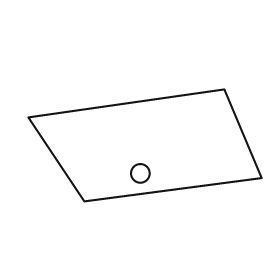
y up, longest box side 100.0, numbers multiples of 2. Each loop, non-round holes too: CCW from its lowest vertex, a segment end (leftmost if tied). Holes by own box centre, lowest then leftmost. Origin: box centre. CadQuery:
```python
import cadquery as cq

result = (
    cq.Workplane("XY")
    .moveTo(-26.0, -24.0)
    .lineTo(50.0, -14.0)
    .lineTo(34.0, 24.0)
    .lineTo(-50.0, 12.0)
    .close()
    .moveTo(-2.0, -12.0)
    .circle(4.0)
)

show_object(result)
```